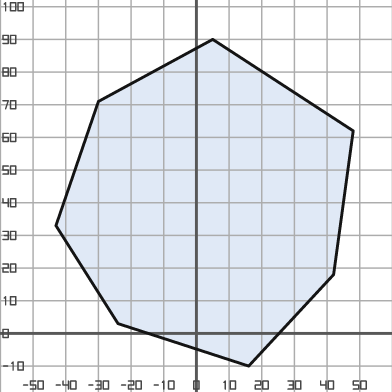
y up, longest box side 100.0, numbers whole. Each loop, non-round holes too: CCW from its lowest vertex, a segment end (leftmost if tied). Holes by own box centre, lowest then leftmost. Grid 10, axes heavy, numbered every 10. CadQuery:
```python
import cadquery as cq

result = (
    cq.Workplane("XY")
    .moveTo(16.0, -10.0)
    .lineTo(42.0, 18.0)
    .lineTo(48.0, 62.0)
    .lineTo(5.0, 90.0)
    .lineTo(-30.0, 71.0)
    .lineTo(-43.0, 33.0)
    .lineTo(-24.0, 3.0)
    .close()
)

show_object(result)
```